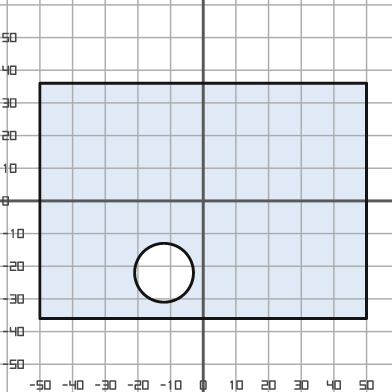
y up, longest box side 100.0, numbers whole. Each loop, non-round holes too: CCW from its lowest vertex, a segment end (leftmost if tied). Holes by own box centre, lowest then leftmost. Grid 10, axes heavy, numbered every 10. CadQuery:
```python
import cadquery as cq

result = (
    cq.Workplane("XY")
    .moveTo(-50.0, -36.0)
    .lineTo(50.0, -36.0)
    .lineTo(50.0, 36.0)
    .lineTo(-50.0, 36.0)
    .close()
    .moveTo(-12.0, -22.0)
    .circle(9.0)
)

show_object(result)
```